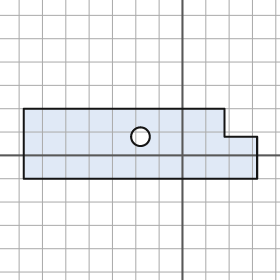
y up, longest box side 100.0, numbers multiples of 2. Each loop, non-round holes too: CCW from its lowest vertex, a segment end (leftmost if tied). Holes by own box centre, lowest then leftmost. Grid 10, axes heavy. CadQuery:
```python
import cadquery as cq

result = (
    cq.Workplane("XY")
    .moveTo(-68.0, -10.0)
    .lineTo(32.0, -10.0)
    .lineTo(32.0, 8.0)
    .lineTo(18.0, 8.0)
    .lineTo(18.0, 20.0)
    .lineTo(-68.0, 20.0)
    .close()
    .moveTo(-18.0, 8.0)
    .circle(4.0)
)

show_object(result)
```